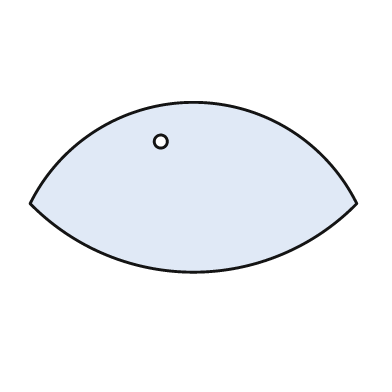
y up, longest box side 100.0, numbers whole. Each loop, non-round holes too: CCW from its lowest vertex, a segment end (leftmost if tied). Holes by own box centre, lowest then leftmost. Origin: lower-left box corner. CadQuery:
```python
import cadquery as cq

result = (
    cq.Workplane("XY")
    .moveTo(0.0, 21.0)
    .threePointArc((50.0, 0.0), (100.0, 21.0))
    .threePointArc((50.0, 52.0), (0.0, 21.0))
    .close()
    .moveTo(40.0, 40.0)
    .circle(2.0)
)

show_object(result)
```